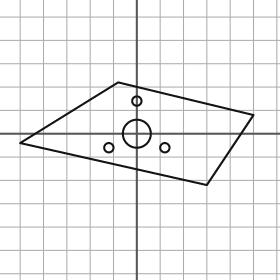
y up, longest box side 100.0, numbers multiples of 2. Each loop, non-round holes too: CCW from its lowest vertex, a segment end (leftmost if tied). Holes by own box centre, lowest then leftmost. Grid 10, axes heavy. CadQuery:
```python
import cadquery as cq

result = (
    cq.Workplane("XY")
    .moveTo(30.0, -22.0)
    .lineTo(50.0, 8.0)
    .lineTo(-8.0, 22.0)
    .lineTo(-50.0, -4.0)
    .close()
    .moveTo(-12.0, -6.0)
    .circle(2.0)
    .moveTo(12.0, -6.0)
    .circle(2.0)
    .moveTo(0.0, 0.0)
    .circle(6.0)
    .moveTo(0.0, 14.0)
    .circle(2.0)
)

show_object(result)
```